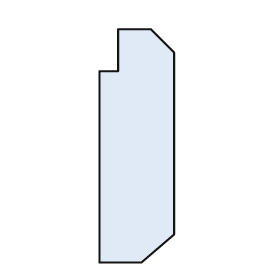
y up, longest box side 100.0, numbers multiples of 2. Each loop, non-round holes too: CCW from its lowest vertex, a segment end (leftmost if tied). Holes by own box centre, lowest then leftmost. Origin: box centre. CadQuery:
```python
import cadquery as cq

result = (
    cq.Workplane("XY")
    .moveTo(-16.0, -50.0)
    .lineTo(2.0, -50.0)
    .lineTo(16.0, -38.0)
    .lineTo(16.0, 40.0)
    .lineTo(6.0, 50.0)
    .lineTo(-8.0, 50.0)
    .lineTo(-8.0, 32.0)
    .lineTo(-16.0, 32.0)
    .close()
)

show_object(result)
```